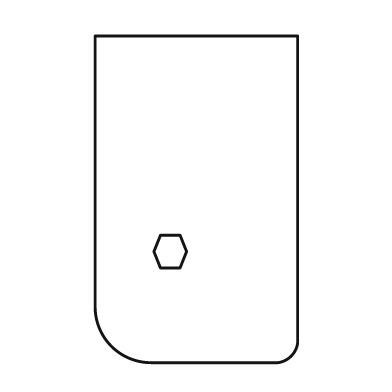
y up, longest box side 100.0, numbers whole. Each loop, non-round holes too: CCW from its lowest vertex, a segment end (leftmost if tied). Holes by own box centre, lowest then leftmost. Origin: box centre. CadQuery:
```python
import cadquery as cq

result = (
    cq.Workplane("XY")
    .moveTo(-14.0, -50.0)
    .lineTo(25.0, -50.0)
    .threePointArc((29.0, -48.0), (31.0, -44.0))
    .lineTo(31.0, 50.0)
    .lineTo(-31.0, 50.0)
    .lineTo(-31.0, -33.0)
    .threePointArc((-26.0, -45.0), (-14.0, -50.0))
    .close()
    .moveTo(-11.0, -21.0)
    .lineTo(-5.0, -21.0)
    .lineTo(-3.0, -16.0)
    .lineTo(-5.0, -11.0)
    .lineTo(-11.0, -11.0)
    .lineTo(-13.0, -16.0)
    .close()
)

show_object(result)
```